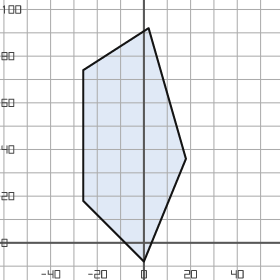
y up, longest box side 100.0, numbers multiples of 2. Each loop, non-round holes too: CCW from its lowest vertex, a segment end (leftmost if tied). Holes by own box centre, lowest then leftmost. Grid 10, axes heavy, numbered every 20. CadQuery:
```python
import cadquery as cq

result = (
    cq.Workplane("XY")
    .moveTo(0.0, -8.0)
    .lineTo(18.0, 36.0)
    .lineTo(2.0, 92.0)
    .lineTo(-26.0, 74.0)
    .lineTo(-26.0, 18.0)
    .close()
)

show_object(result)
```